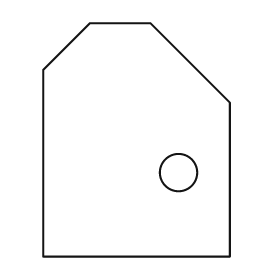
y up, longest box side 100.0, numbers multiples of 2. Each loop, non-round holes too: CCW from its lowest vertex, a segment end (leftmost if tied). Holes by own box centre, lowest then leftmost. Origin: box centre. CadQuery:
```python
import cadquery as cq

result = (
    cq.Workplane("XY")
    .moveTo(-40.0, -50.0)
    .lineTo(40.0, -50.0)
    .lineTo(40.0, 16.0)
    .lineTo(6.0, 50.0)
    .lineTo(-20.0, 50.0)
    .lineTo(-40.0, 30.0)
    .close()
    .moveTo(18.0, -14.0)
    .circle(8.0)
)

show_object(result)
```